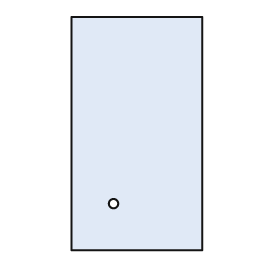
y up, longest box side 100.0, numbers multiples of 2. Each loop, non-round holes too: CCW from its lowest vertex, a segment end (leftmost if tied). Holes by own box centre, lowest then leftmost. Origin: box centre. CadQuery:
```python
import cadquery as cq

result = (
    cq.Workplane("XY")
    .moveTo(-28.0, -50.0)
    .lineTo(28.0, -50.0)
    .lineTo(28.0, 50.0)
    .lineTo(-28.0, 50.0)
    .close()
    .moveTo(-10.0, -30.0)
    .circle(2.0)
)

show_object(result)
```